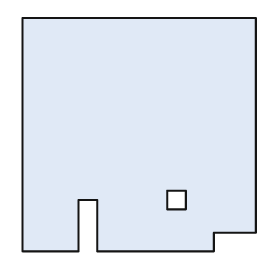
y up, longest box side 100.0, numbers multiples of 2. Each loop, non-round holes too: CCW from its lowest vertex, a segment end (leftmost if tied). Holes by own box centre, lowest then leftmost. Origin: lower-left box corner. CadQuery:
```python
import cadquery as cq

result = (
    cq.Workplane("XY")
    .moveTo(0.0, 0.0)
    .lineTo(24.0, 0.0)
    .lineTo(24.0, 22.0)
    .lineTo(32.0, 22.0)
    .lineTo(32.0, 0.0)
    .lineTo(82.0, 0.0)
    .lineTo(82.0, 8.0)
    .lineTo(100.0, 8.0)
    .lineTo(100.0, 100.0)
    .lineTo(0.0, 100.0)
    .close()
    .moveTo(62.0, 18.0)
    .lineTo(70.0, 18.0)
    .lineTo(70.0, 26.0)
    .lineTo(62.0, 26.0)
    .close()
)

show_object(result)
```